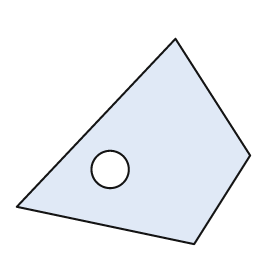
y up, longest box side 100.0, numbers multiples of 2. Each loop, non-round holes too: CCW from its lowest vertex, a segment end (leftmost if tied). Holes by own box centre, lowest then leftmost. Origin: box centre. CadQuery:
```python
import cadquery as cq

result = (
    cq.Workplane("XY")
    .moveTo(26.0, -44.0)
    .lineTo(50.0, -6.0)
    .lineTo(18.0, 44.0)
    .lineTo(-50.0, -28.0)
    .close()
    .moveTo(-10.0, -12.0)
    .circle(8.0)
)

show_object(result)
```